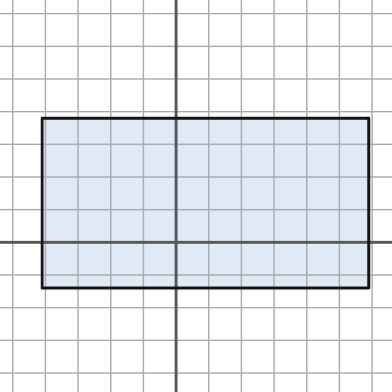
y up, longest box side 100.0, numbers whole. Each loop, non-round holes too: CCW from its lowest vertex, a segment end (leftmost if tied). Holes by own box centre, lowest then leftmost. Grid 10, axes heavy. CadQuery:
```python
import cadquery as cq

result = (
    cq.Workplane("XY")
    .moveTo(-41.0, -14.0)
    .lineTo(59.0, -14.0)
    .lineTo(59.0, 38.0)
    .lineTo(-41.0, 38.0)
    .close()
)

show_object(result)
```